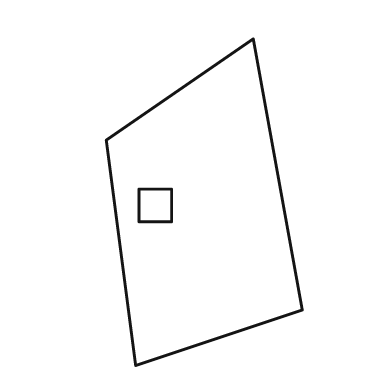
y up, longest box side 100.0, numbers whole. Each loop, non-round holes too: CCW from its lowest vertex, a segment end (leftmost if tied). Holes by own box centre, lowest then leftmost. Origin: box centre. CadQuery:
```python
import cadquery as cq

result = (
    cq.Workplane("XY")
    .moveTo(-21.0, -50.0)
    .lineTo(30.0, -33.0)
    .lineTo(15.0, 50.0)
    .lineTo(-30.0, 19.0)
    .close()
    .moveTo(-20.0, -6.0)
    .lineTo(-10.0, -6.0)
    .lineTo(-10.0, 4.0)
    .lineTo(-20.0, 4.0)
    .close()
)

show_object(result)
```